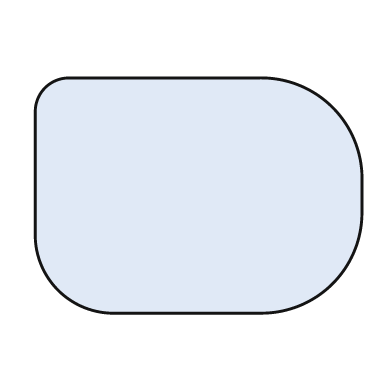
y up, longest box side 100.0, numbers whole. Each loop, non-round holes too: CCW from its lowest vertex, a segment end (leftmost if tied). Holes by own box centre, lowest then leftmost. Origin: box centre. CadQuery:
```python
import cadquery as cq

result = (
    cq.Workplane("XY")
    .moveTo(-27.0, -36.0)
    .lineTo(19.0, -36.0)
    .threePointArc((41.0, -27.0), (50.0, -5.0))
    .lineTo(50.0, 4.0)
    .threePointArc((41.0, 27.0), (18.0, 36.0))
    .lineTo(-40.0, 36.0)
    .threePointArc((-47.0, 33.0), (-50.0, 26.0))
    .lineTo(-50.0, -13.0)
    .threePointArc((-43.0, -29.0), (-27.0, -36.0))
    .close()
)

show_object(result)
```